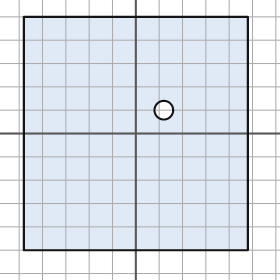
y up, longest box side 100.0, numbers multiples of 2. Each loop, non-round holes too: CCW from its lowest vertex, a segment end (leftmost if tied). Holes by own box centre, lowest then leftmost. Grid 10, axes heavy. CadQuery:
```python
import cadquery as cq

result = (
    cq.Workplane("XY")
    .moveTo(-48.0, -50.0)
    .lineTo(48.0, -50.0)
    .lineTo(48.0, 50.0)
    .lineTo(-48.0, 50.0)
    .close()
    .moveTo(12.0, 10.0)
    .circle(4.0)
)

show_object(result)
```